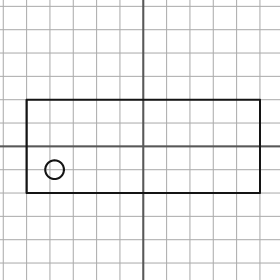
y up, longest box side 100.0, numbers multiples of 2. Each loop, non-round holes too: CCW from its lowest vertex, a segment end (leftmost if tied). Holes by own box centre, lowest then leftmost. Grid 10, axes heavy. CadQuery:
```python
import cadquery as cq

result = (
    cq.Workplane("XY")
    .moveTo(-50.0, -20.0)
    .lineTo(50.0, -20.0)
    .lineTo(50.0, 20.0)
    .lineTo(-50.0, 20.0)
    .close()
    .moveTo(-38.0, -10.0)
    .circle(4.0)
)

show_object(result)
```